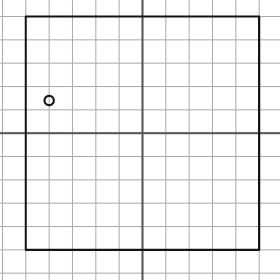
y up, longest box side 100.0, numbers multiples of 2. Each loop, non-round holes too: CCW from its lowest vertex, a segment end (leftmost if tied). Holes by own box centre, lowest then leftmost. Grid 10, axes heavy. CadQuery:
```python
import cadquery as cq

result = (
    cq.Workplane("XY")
    .moveTo(-50.0, -50.0)
    .lineTo(50.0, -50.0)
    .lineTo(50.0, 50.0)
    .lineTo(-50.0, 50.0)
    .close()
    .moveTo(-40.0, 14.0)
    .circle(2.0)
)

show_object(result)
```